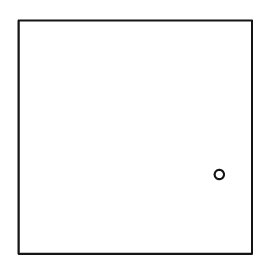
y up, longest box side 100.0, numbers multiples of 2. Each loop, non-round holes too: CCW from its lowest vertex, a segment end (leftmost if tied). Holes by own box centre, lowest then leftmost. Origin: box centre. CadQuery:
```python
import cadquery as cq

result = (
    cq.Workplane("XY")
    .moveTo(-50.0, -50.0)
    .lineTo(50.0, -50.0)
    .lineTo(50.0, 50.0)
    .lineTo(-50.0, 50.0)
    .close()
    .moveTo(36.0, -16.0)
    .circle(2.0)
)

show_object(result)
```